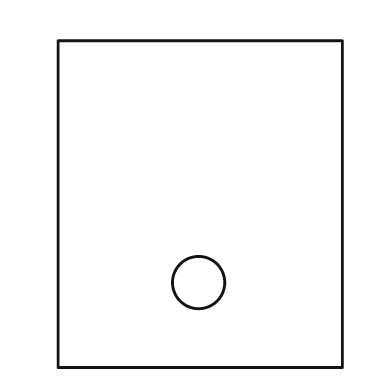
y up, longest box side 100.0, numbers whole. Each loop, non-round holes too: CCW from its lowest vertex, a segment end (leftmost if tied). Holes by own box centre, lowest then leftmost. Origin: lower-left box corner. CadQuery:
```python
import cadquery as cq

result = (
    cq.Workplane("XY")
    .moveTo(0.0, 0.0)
    .lineTo(87.0, 0.0)
    .lineTo(87.0, 100.0)
    .lineTo(0.0, 100.0)
    .close()
    .moveTo(43.0, 26.0)
    .circle(8.0)
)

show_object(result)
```